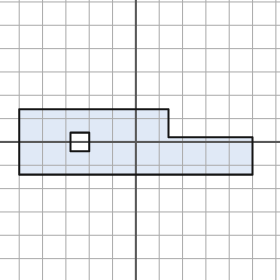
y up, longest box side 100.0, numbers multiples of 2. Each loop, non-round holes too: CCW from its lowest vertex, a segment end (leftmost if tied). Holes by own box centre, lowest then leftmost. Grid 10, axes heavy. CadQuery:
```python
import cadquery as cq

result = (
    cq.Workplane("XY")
    .moveTo(-50.0, -14.0)
    .lineTo(50.0, -14.0)
    .lineTo(50.0, 2.0)
    .lineTo(14.0, 2.0)
    .lineTo(14.0, 14.0)
    .lineTo(-50.0, 14.0)
    .close()
    .moveTo(-28.0, -4.0)
    .lineTo(-20.0, -4.0)
    .lineTo(-20.0, 4.0)
    .lineTo(-28.0, 4.0)
    .close()
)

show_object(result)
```